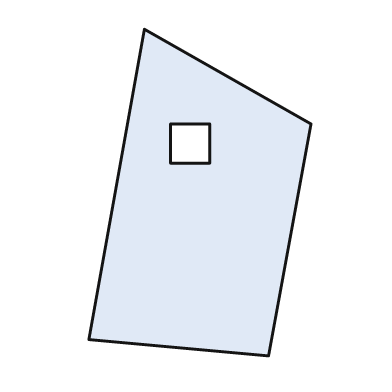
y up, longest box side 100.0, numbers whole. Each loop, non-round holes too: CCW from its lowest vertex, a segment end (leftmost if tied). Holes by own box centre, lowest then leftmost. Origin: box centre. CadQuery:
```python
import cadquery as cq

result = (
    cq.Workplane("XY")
    .moveTo(21.0, -50.0)
    .lineTo(34.0, 21.0)
    .lineTo(-17.0, 50.0)
    .lineTo(-34.0, -45.0)
    .close()
    .moveTo(-9.0, 9.0)
    .lineTo(3.0, 9.0)
    .lineTo(3.0, 21.0)
    .lineTo(-9.0, 21.0)
    .close()
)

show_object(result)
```